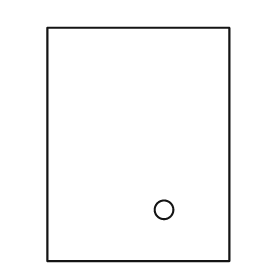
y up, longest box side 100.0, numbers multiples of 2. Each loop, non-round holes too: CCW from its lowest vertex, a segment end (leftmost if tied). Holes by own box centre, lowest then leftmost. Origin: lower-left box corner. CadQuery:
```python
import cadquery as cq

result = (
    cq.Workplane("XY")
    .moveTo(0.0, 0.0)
    .lineTo(78.0, 0.0)
    .lineTo(78.0, 100.0)
    .lineTo(0.0, 100.0)
    .close()
    .moveTo(50.0, 22.0)
    .circle(4.0)
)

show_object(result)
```